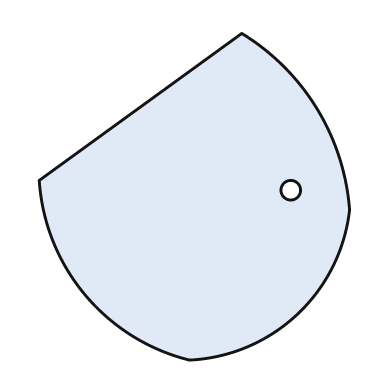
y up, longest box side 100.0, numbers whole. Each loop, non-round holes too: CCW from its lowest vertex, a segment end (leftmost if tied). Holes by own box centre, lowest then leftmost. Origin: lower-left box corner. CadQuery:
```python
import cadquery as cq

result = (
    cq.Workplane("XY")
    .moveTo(46.0, 0.0)
    .threePointArc((79.0, 14.0), (95.0, 46.0))
    .threePointArc((85.0, 77.0), (62.0, 100.0))
    .lineTo(0.0, 55.0)
    .threePointArc((14.0, 20.0), (46.0, 0.0))
    .close()
    .moveTo(77.0, 52.0)
    .circle(3.0)
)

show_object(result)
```